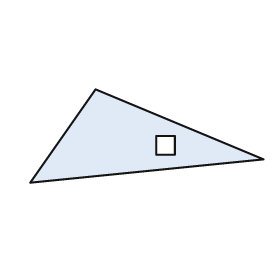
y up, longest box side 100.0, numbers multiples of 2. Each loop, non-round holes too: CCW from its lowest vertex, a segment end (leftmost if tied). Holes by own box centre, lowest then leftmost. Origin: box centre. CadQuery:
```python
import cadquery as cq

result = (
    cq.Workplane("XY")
    .moveTo(-50.0, -20.0)
    .lineTo(50.0, -10.0)
    .lineTo(-22.0, 20.0)
    .close()
    .moveTo(4.0, -8.0)
    .lineTo(12.0, -8.0)
    .lineTo(12.0, 0.0)
    .lineTo(4.0, 0.0)
    .close()
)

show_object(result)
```